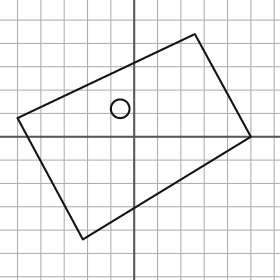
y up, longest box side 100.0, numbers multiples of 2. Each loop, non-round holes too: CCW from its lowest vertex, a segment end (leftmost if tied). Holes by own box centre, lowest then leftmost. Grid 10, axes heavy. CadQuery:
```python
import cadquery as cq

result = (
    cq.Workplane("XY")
    .moveTo(-22.0, -44.0)
    .lineTo(50.0, 0.0)
    .lineTo(26.0, 44.0)
    .lineTo(-50.0, 8.0)
    .close()
    .moveTo(-6.0, 12.0)
    .circle(4.0)
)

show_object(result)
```